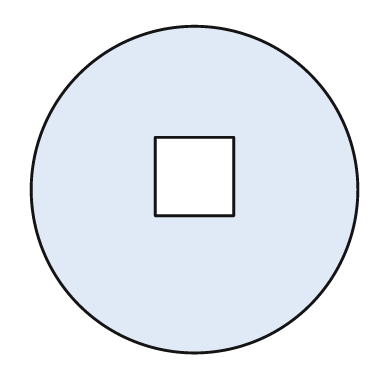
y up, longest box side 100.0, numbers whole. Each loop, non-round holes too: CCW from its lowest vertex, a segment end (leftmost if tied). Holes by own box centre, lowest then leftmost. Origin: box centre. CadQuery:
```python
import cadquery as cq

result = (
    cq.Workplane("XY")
    .moveTo(0.0, 0.0)
    .circle(50.0)
    .moveTo(-12.0, -8.0)
    .lineTo(12.0, -8.0)
    .lineTo(12.0, 16.0)
    .lineTo(-12.0, 16.0)
    .close()
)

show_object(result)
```